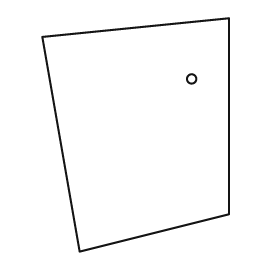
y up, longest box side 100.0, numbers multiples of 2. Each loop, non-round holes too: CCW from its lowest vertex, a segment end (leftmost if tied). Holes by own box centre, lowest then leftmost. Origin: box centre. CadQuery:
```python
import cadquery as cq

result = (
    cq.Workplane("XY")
    .moveTo(-24.0, -50.0)
    .lineTo(40.0, -34.0)
    .lineTo(40.0, 50.0)
    .lineTo(-40.0, 42.0)
    .close()
    .moveTo(24.0, 24.0)
    .circle(2.0)
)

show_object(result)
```